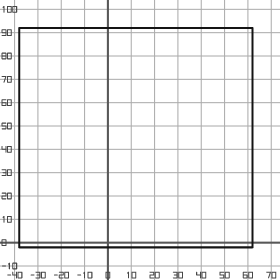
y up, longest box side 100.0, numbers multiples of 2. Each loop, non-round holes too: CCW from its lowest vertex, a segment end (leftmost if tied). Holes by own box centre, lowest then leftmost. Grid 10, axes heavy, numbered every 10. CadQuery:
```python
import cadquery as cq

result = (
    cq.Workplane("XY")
    .moveTo(-38.0, -2.0)
    .lineTo(62.0, -2.0)
    .lineTo(62.0, 92.0)
    .lineTo(-38.0, 92.0)
    .close()
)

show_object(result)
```